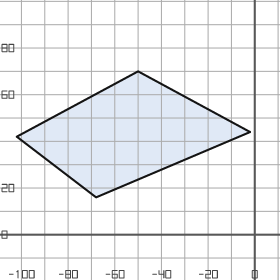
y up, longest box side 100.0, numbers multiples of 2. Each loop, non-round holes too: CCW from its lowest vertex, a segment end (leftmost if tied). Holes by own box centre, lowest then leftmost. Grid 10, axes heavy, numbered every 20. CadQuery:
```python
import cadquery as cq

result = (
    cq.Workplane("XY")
    .moveTo(-68.0, 16.0)
    .lineTo(-2.0, 44.0)
    .lineTo(-50.0, 70.0)
    .lineTo(-102.0, 42.0)
    .close()
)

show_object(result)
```